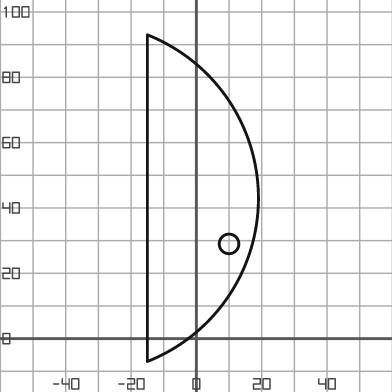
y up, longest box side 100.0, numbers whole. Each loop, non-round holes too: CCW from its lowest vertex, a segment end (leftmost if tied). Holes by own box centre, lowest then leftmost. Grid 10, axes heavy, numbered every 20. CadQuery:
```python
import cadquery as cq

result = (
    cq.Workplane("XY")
    .moveTo(-15.0, -7.0)
    .threePointArc((19.0, 43.0), (-15.0, 93.0))
    .close()
    .moveTo(10.0, 29.0)
    .circle(3.0)
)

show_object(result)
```